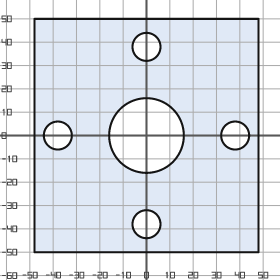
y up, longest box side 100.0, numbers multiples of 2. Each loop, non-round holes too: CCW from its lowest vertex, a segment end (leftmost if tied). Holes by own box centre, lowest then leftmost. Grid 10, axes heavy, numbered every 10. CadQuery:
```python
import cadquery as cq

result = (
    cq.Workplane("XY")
    .moveTo(-48.0, -50.0)
    .lineTo(48.0, -50.0)
    .lineTo(48.0, 50.0)
    .lineTo(-48.0, 50.0)
    .close()
    .moveTo(0.0, -38.0)
    .circle(6.0)
    .moveTo(-38.0, 0.0)
    .circle(6.0)
    .moveTo(0.0, 0.0)
    .circle(16.0)
    .moveTo(38.0, 0.0)
    .circle(6.0)
    .moveTo(0.0, 38.0)
    .circle(6.0)
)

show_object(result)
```